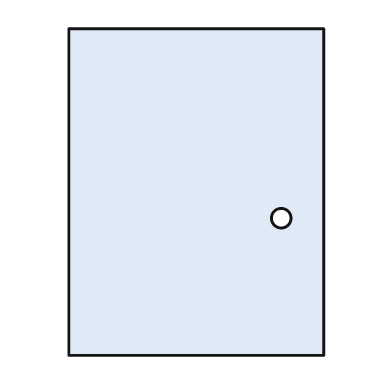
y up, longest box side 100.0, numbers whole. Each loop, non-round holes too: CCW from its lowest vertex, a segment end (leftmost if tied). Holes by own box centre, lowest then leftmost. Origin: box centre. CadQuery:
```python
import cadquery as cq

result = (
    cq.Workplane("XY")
    .moveTo(-39.0, -50.0)
    .lineTo(39.0, -50.0)
    .lineTo(39.0, 50.0)
    .lineTo(-39.0, 50.0)
    .close()
    .moveTo(26.0, -8.0)
    .circle(3.0)
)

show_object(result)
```